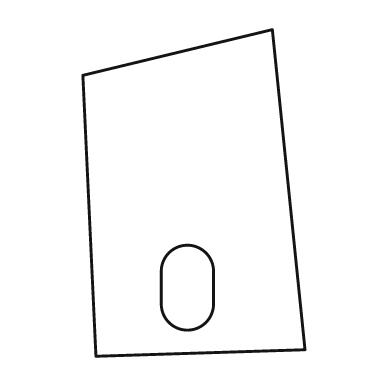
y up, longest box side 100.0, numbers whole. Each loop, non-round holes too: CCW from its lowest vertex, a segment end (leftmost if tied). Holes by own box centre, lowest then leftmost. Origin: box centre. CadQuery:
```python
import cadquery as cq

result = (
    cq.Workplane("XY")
    .moveTo(-30.0, -50.0)
    .lineTo(34.0, -48.0)
    .lineTo(24.0, 50.0)
    .lineTo(-34.0, 36.0)
    .close()
    .moveTo(-10.0, -34.0)
    .threePointArc((-2.0, -42.0), (6.0, -34.0))
    .lineTo(6.0, -24.0)
    .threePointArc((-2.0, -16.0), (-10.0, -24.0))
    .close()
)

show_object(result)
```